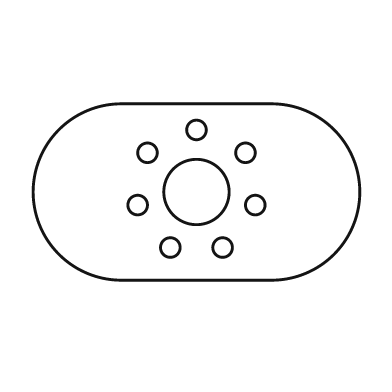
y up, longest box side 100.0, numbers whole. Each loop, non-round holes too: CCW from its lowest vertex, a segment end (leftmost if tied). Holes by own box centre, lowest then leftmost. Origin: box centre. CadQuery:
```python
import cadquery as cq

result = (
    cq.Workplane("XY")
    .moveTo(-23.0, -27.0)
    .lineTo(23.0, -27.0)
    .threePointArc((50.0, 0.0), (23.0, 27.0))
    .lineTo(-23.0, 27.0)
    .threePointArc((-50.0, 0.0), (-23.0, -27.0))
    .close()
    .moveTo(-8.0, -17.0)
    .circle(3.0)
    .moveTo(8.0, -17.0)
    .circle(3.0)
    .moveTo(-18.0, -4.0)
    .circle(3.0)
    .moveTo(18.0, -4.0)
    .circle(3.0)
    .moveTo(0.0, 0.0)
    .circle(10.0)
    .moveTo(-15.0, 12.0)
    .circle(3.0)
    .moveTo(15.0, 12.0)
    .circle(3.0)
    .moveTo(0.0, 19.0)
    .circle(3.0)
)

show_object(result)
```